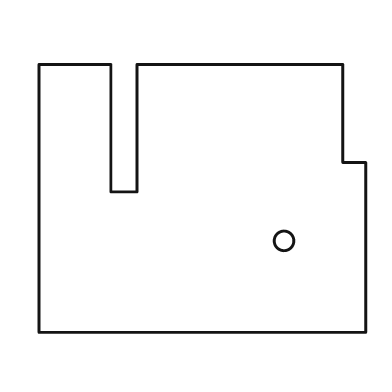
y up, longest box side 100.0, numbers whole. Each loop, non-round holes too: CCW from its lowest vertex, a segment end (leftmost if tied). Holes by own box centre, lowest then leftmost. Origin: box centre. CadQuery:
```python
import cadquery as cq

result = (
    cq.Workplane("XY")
    .moveTo(-50.0, -41.0)
    .lineTo(50.0, -41.0)
    .lineTo(50.0, 11.0)
    .lineTo(43.0, 11.0)
    .lineTo(43.0, 41.0)
    .lineTo(-20.0, 41.0)
    .lineTo(-20.0, 2.0)
    .lineTo(-28.0, 2.0)
    .lineTo(-28.0, 41.0)
    .lineTo(-50.0, 41.0)
    .close()
    .moveTo(25.0, -13.0)
    .circle(3.0)
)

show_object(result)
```